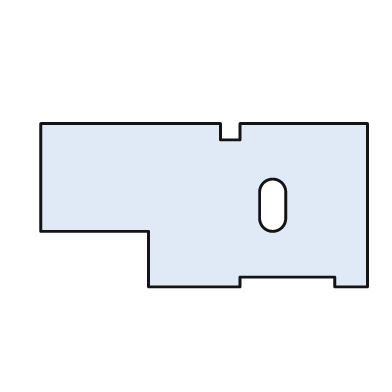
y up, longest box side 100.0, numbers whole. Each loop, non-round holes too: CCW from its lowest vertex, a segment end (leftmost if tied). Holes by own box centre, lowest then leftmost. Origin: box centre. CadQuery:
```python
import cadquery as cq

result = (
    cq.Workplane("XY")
    .moveTo(-17.0, -25.0)
    .lineTo(11.0, -25.0)
    .lineTo(11.0, -22.0)
    .lineTo(40.0, -22.0)
    .lineTo(40.0, -25.0)
    .lineTo(50.0, -25.0)
    .lineTo(50.0, 25.0)
    .lineTo(11.0, 25.0)
    .lineTo(11.0, 20.0)
    .lineTo(5.0, 20.0)
    .lineTo(5.0, 25.0)
    .lineTo(-50.0, 25.0)
    .lineTo(-50.0, -8.0)
    .lineTo(-17.0, -8.0)
    .close()
    .moveTo(17.0, -4.0)
    .threePointArc((21.0, -8.0), (25.0, -4.0))
    .lineTo(25.0, 4.0)
    .threePointArc((21.0, 8.0), (17.0, 4.0))
    .close()
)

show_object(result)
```